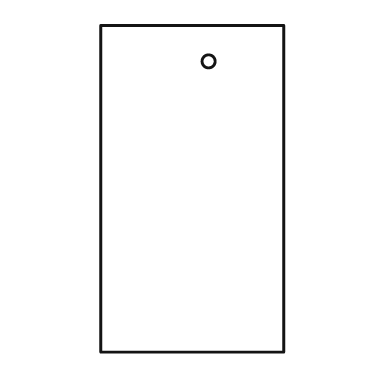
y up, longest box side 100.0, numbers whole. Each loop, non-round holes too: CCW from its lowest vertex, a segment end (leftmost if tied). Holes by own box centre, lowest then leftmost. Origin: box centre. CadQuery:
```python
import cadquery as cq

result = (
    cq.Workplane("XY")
    .moveTo(-28.0, -50.0)
    .lineTo(28.0, -50.0)
    .lineTo(28.0, 50.0)
    .lineTo(-28.0, 50.0)
    .close()
    .moveTo(5.0, 39.0)
    .circle(2.0)
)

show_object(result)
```